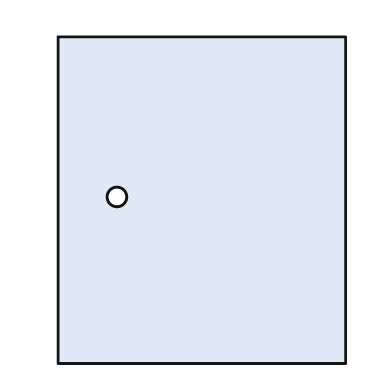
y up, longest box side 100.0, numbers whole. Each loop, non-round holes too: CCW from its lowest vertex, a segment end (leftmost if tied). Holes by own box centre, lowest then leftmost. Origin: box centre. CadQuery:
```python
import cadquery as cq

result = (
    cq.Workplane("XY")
    .moveTo(-44.0, -50.0)
    .lineTo(44.0, -50.0)
    .lineTo(44.0, 50.0)
    .lineTo(-44.0, 50.0)
    .close()
    .moveTo(-26.0, 1.0)
    .circle(3.0)
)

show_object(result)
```